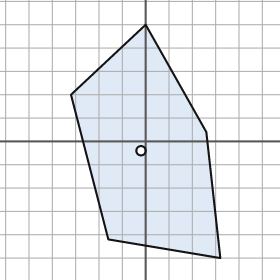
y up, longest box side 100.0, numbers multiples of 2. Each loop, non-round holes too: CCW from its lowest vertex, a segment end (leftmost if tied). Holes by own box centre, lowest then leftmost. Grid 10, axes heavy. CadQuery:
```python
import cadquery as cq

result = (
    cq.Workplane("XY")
    .moveTo(32.0, -50.0)
    .lineTo(26.0, 4.0)
    .lineTo(0.0, 50.0)
    .lineTo(-32.0, 20.0)
    .lineTo(-16.0, -42.0)
    .close()
    .moveTo(-2.0, -4.0)
    .circle(2.0)
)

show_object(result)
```